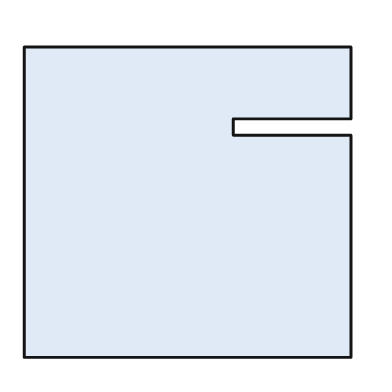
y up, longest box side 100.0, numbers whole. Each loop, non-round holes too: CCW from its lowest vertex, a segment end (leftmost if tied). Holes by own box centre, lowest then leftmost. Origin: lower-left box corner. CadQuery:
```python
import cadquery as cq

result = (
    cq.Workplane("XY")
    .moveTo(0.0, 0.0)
    .lineTo(100.0, 0.0)
    .lineTo(100.0, 68.0)
    .lineTo(64.0, 68.0)
    .lineTo(64.0, 73.0)
    .lineTo(100.0, 73.0)
    .lineTo(100.0, 95.0)
    .lineTo(0.0, 95.0)
    .close()
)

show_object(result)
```